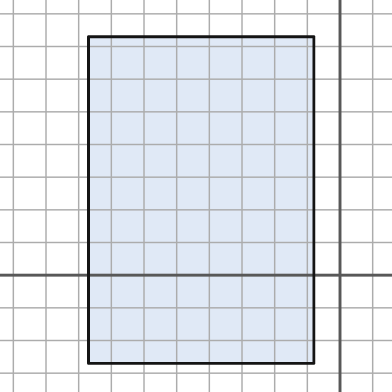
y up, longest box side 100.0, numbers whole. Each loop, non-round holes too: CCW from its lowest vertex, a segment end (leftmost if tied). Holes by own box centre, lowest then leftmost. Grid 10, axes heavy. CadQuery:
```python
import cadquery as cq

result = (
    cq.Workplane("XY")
    .moveTo(-77.0, -27.0)
    .lineTo(-8.0, -27.0)
    .lineTo(-8.0, 73.0)
    .lineTo(-77.0, 73.0)
    .close()
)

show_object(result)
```